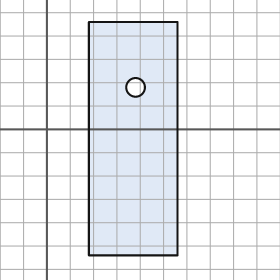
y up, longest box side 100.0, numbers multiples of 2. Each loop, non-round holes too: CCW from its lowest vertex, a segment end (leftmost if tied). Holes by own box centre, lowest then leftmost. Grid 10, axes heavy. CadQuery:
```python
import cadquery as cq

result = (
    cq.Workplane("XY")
    .moveTo(18.0, -54.0)
    .lineTo(56.0, -54.0)
    .lineTo(56.0, 46.0)
    .lineTo(18.0, 46.0)
    .close()
    .moveTo(38.0, 18.0)
    .circle(4.0)
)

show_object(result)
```